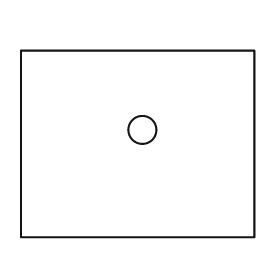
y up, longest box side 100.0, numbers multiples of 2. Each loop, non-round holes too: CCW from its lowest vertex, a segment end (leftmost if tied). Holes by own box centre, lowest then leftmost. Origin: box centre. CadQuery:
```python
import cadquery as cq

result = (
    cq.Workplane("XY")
    .moveTo(-50.0, -40.0)
    .lineTo(50.0, -40.0)
    .lineTo(50.0, 40.0)
    .lineTo(-50.0, 40.0)
    .close()
    .moveTo(2.0, 6.0)
    .circle(6.0)
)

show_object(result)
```